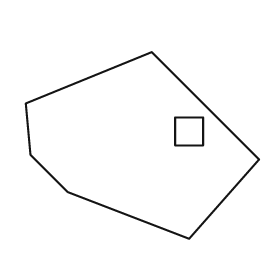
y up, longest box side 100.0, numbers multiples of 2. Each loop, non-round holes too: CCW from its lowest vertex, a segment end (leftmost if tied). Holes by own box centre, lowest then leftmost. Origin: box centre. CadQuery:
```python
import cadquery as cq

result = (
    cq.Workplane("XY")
    .moveTo(20.0, -40.0)
    .lineTo(50.0, -6.0)
    .lineTo(4.0, 40.0)
    .lineTo(-50.0, 18.0)
    .lineTo(-48.0, -4.0)
    .lineTo(-32.0, -20.0)
    .close()
    .moveTo(14.0, 0.0)
    .lineTo(26.0, 0.0)
    .lineTo(26.0, 12.0)
    .lineTo(14.0, 12.0)
    .close()
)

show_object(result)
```